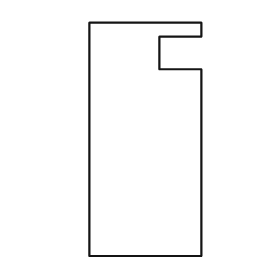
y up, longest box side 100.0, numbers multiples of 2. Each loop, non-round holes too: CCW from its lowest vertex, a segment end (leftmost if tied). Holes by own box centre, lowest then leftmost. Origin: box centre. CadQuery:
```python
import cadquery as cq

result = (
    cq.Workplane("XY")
    .moveTo(-24.0, -50.0)
    .lineTo(24.0, -50.0)
    .lineTo(24.0, 30.0)
    .lineTo(6.0, 30.0)
    .lineTo(6.0, 44.0)
    .lineTo(24.0, 44.0)
    .lineTo(24.0, 50.0)
    .lineTo(-24.0, 50.0)
    .close()
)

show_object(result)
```